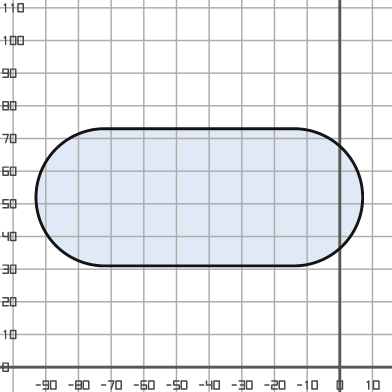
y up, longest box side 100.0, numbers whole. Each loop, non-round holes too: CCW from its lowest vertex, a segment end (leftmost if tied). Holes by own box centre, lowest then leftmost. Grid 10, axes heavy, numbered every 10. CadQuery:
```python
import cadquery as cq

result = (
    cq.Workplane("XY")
    .moveTo(-72.0, 31.0)
    .lineTo(-14.0, 31.0)
    .threePointArc((7.0, 52.0), (-14.0, 73.0))
    .lineTo(-72.0, 73.0)
    .threePointArc((-93.0, 52.0), (-72.0, 31.0))
    .close()
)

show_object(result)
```